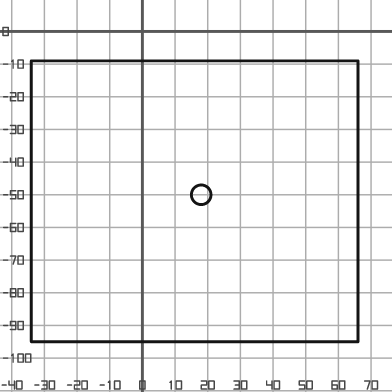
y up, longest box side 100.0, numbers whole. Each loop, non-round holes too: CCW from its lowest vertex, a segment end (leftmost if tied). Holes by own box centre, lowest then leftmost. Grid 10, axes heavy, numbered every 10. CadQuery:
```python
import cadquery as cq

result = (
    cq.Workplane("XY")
    .moveTo(-34.0, -95.0)
    .lineTo(66.0, -95.0)
    .lineTo(66.0, -9.0)
    .lineTo(-34.0, -9.0)
    .close()
    .moveTo(18.0, -50.0)
    .circle(3.0)
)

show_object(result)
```